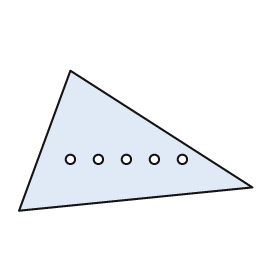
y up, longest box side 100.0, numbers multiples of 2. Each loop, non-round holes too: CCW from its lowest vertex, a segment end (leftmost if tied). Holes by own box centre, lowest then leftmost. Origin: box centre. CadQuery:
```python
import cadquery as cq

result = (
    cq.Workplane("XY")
    .moveTo(-50.0, -30.0)
    .lineTo(50.0, -20.0)
    .lineTo(-28.0, 30.0)
    .close()
    .moveTo(-28.0, -8.0)
    .circle(2.0)
    .moveTo(-16.0, -8.0)
    .circle(2.0)
    .moveTo(-4.0, -8.0)
    .circle(2.0)
    .moveTo(8.0, -8.0)
    .circle(2.0)
    .moveTo(20.0, -8.0)
    .circle(2.0)
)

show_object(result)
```